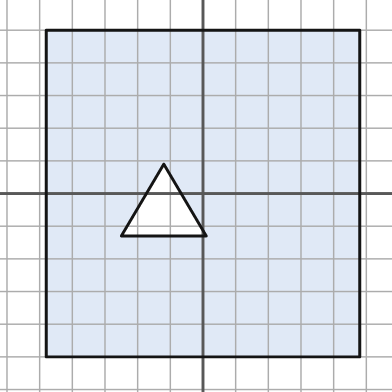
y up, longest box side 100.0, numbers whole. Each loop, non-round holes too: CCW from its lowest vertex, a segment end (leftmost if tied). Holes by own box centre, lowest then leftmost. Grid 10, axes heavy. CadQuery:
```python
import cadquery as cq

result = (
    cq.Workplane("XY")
    .moveTo(-48.0, -50.0)
    .lineTo(48.0, -50.0)
    .lineTo(48.0, 50.0)
    .lineTo(-48.0, 50.0)
    .close()
    .moveTo(-25.0, -13.0)
    .lineTo(1.0, -13.0)
    .lineTo(-12.0, 9.0)
    .close()
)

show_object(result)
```